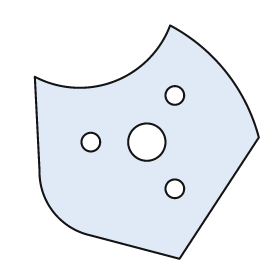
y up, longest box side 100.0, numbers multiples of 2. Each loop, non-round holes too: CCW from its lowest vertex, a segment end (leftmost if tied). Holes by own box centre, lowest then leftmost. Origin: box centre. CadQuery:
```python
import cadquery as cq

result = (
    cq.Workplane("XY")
    .moveTo(14.0, -50.0)
    .lineTo(48.0, 2.0)
    .threePointArc((34.0, 30.0), (10.0, 50.0))
    .threePointArc((-14.0, 26.0), (-48.0, 28.0))
    .lineTo(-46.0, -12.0)
    .threePointArc((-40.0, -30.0), (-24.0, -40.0))
    .close()
    .moveTo(12.0, -20.0)
    .circle(4.0)
    .moveTo(-24.0, 0.0)
    .circle(4.0)
    .moveTo(0.0, 0.0)
    .circle(8.0)
    .moveTo(12.0, 20.0)
    .circle(4.0)
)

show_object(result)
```